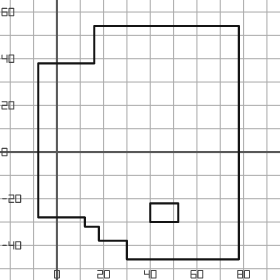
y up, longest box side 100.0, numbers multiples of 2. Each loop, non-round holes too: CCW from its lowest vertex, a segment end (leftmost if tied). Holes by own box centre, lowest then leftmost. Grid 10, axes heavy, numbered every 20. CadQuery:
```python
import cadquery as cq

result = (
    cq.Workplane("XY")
    .moveTo(30.0, -46.0)
    .lineTo(78.0, -46.0)
    .lineTo(78.0, 54.0)
    .lineTo(16.0, 54.0)
    .lineTo(16.0, 38.0)
    .lineTo(-8.0, 38.0)
    .lineTo(-8.0, -28.0)
    .lineTo(12.0, -28.0)
    .lineTo(12.0, -32.0)
    .lineTo(18.0, -32.0)
    .lineTo(18.0, -38.0)
    .lineTo(30.0, -38.0)
    .close()
    .moveTo(40.0, -30.0)
    .lineTo(52.0, -30.0)
    .lineTo(52.0, -22.0)
    .lineTo(40.0, -22.0)
    .close()
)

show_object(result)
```